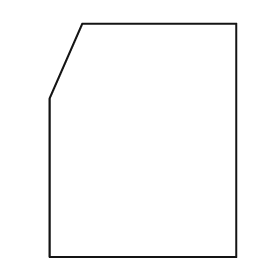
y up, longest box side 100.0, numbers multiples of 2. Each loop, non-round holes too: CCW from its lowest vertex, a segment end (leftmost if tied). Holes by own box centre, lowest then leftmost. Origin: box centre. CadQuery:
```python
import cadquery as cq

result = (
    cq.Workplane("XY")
    .moveTo(-40.0, -50.0)
    .lineTo(40.0, -50.0)
    .lineTo(40.0, 50.0)
    .lineTo(-26.0, 50.0)
    .lineTo(-40.0, 18.0)
    .close()
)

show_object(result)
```